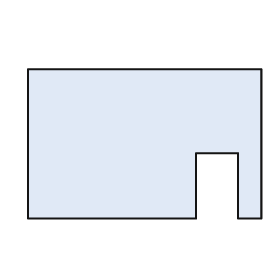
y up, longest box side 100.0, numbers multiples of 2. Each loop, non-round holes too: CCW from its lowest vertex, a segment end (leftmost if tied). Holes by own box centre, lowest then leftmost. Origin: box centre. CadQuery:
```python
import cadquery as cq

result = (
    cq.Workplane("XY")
    .moveTo(-50.0, -32.0)
    .lineTo(22.0, -32.0)
    .lineTo(22.0, -4.0)
    .lineTo(40.0, -4.0)
    .lineTo(40.0, -32.0)
    .lineTo(50.0, -32.0)
    .lineTo(50.0, 32.0)
    .lineTo(-50.0, 32.0)
    .close()
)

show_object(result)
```